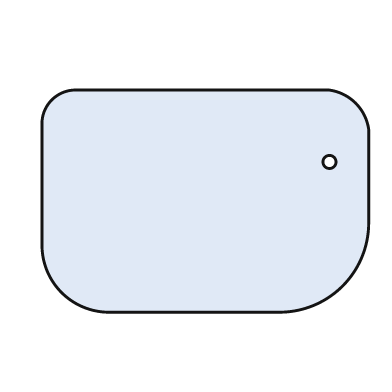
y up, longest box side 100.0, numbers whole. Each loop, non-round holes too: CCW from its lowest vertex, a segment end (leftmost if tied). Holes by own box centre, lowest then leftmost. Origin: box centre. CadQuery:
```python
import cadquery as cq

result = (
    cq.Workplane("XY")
    .moveTo(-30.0, -34.0)
    .lineTo(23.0, -34.0)
    .threePointArc((42.0, -26.0), (50.0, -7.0))
    .lineTo(50.0, 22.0)
    .threePointArc((46.0, 30.0), (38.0, 34.0))
    .lineTo(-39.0, 34.0)
    .threePointArc((-47.0, 31.0), (-50.0, 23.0))
    .lineTo(-50.0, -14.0)
    .threePointArc((-44.0, -28.0), (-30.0, -34.0))
    .close()
    .moveTo(38.0, 12.0)
    .circle(2.0)
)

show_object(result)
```